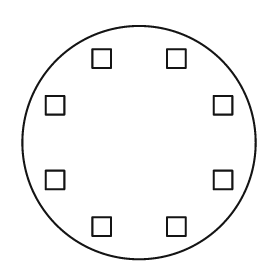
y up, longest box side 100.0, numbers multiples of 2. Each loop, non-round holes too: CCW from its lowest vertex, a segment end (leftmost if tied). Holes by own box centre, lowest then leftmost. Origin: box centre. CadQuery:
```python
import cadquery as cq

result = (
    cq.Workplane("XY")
    .moveTo(0.0, 0.0)
    .circle(50.0)
    .moveTo(-20.0, -40.0)
    .lineTo(-12.0, -40.0)
    .lineTo(-12.0, -32.0)
    .lineTo(-20.0, -32.0)
    .close()
    .moveTo(12.0, -40.0)
    .lineTo(20.0, -40.0)
    .lineTo(20.0, -32.0)
    .lineTo(12.0, -32.0)
    .close()
    .moveTo(-40.0, -20.0)
    .lineTo(-32.0, -20.0)
    .lineTo(-32.0, -12.0)
    .lineTo(-40.0, -12.0)
    .close()
    .moveTo(32.0, -20.0)
    .lineTo(40.0, -20.0)
    .lineTo(40.0, -12.0)
    .lineTo(32.0, -12.0)
    .close()
    .moveTo(-40.0, 12.0)
    .lineTo(-32.0, 12.0)
    .lineTo(-32.0, 20.0)
    .lineTo(-40.0, 20.0)
    .close()
    .moveTo(32.0, 12.0)
    .lineTo(40.0, 12.0)
    .lineTo(40.0, 20.0)
    .lineTo(32.0, 20.0)
    .close()
    .moveTo(-20.0, 32.0)
    .lineTo(-12.0, 32.0)
    .lineTo(-12.0, 40.0)
    .lineTo(-20.0, 40.0)
    .close()
    .moveTo(12.0, 32.0)
    .lineTo(20.0, 32.0)
    .lineTo(20.0, 40.0)
    .lineTo(12.0, 40.0)
    .close()
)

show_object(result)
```